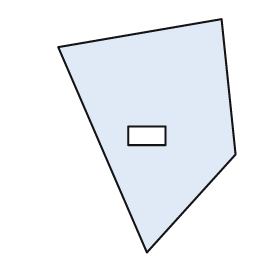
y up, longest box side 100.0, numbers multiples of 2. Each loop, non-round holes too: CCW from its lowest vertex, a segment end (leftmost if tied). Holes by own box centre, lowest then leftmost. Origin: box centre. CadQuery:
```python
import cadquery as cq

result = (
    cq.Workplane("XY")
    .moveTo(0.0, -50.0)
    .lineTo(38.0, -8.0)
    .lineTo(32.0, 50.0)
    .lineTo(-38.0, 38.0)
    .close()
    .moveTo(-8.0, -4.0)
    .lineTo(8.0, -4.0)
    .lineTo(8.0, 4.0)
    .lineTo(-8.0, 4.0)
    .close()
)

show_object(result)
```